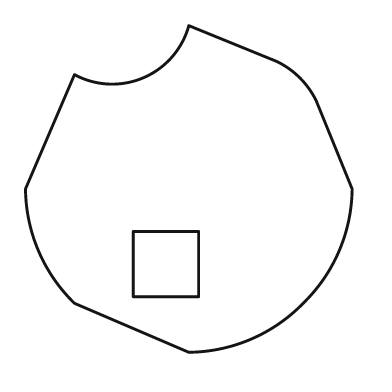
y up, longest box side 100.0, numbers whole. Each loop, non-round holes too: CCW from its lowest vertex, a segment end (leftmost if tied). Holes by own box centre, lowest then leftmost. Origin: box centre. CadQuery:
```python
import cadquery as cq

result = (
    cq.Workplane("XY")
    .moveTo(0.0, -50.0)
    .threePointArc((19.0, -46.0), (35.0, -35.0))
    .threePointArc((46.0, -19.0), (50.0, 0.0))
    .lineTo(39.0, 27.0)
    .threePointArc((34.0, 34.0), (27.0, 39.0))
    .lineTo(0.0, 50.0)
    .threePointArc((-14.0, 34.0), (-35.0, 35.0))
    .lineTo(-50.0, 0.0)
    .threePointArc((-46.0, -19.0), (-35.0, -35.0))
    .close()
    .moveTo(-17.0, -33.0)
    .lineTo(3.0, -33.0)
    .lineTo(3.0, -13.0)
    .lineTo(-17.0, -13.0)
    .close()
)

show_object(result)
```